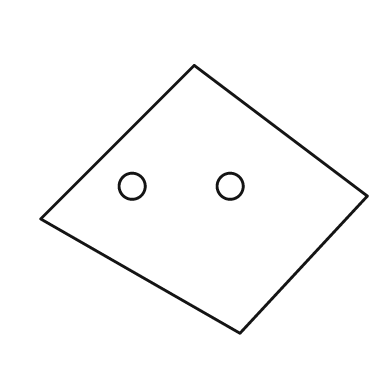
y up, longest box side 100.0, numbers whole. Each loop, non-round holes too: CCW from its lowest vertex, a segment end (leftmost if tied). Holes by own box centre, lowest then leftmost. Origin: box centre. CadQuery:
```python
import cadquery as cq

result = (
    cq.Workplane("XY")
    .moveTo(11.0, -41.0)
    .lineTo(50.0, 1.0)
    .lineTo(-3.0, 41.0)
    .lineTo(-50.0, -6.0)
    .close()
    .moveTo(-22.0, 4.0)
    .circle(4.0)
    .moveTo(8.0, 4.0)
    .circle(4.0)
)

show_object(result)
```